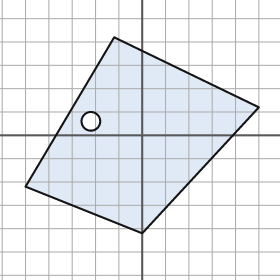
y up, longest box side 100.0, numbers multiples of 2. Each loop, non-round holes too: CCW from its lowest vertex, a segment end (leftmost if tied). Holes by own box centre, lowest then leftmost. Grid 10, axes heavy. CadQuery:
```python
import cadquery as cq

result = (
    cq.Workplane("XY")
    .moveTo(0.0, -42.0)
    .lineTo(50.0, 12.0)
    .lineTo(-12.0, 42.0)
    .lineTo(-50.0, -22.0)
    .close()
    .moveTo(-22.0, 6.0)
    .circle(4.0)
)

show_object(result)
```